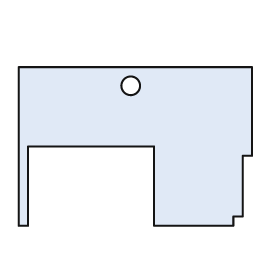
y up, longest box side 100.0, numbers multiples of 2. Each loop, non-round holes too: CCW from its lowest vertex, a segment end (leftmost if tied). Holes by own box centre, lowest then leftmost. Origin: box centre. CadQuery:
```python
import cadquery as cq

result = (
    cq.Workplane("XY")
    .moveTo(-50.0, -34.0)
    .lineTo(-46.0, -34.0)
    .lineTo(-46.0, 0.0)
    .lineTo(8.0, 0.0)
    .lineTo(8.0, -34.0)
    .lineTo(42.0, -34.0)
    .lineTo(42.0, -30.0)
    .lineTo(46.0, -30.0)
    .lineTo(46.0, -4.0)
    .lineTo(50.0, -4.0)
    .lineTo(50.0, 34.0)
    .lineTo(-50.0, 34.0)
    .close()
    .moveTo(-2.0, 26.0)
    .circle(4.0)
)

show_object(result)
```